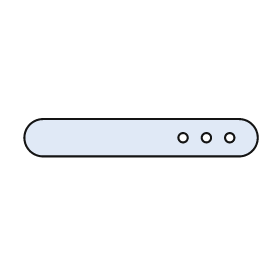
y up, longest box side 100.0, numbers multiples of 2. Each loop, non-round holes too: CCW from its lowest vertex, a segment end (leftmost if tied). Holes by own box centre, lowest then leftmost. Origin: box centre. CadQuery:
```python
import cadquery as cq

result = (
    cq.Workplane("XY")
    .moveTo(-42.0, -8.0)
    .lineTo(42.0, -8.0)
    .threePointArc((50.0, 0.0), (42.0, 8.0))
    .lineTo(-42.0, 8.0)
    .threePointArc((-50.0, 0.0), (-42.0, -8.0))
    .close()
    .moveTo(18.0, 0.0)
    .circle(2.0)
    .moveTo(28.0, 0.0)
    .circle(2.0)
    .moveTo(38.0, 0.0)
    .circle(2.0)
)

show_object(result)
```